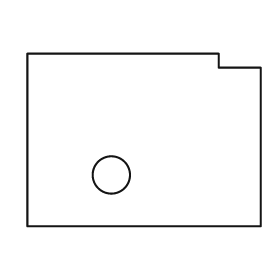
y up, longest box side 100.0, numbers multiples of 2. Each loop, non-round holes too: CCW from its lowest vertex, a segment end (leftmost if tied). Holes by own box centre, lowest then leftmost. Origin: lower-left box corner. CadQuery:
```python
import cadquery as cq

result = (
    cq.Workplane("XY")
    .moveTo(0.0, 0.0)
    .lineTo(100.0, 0.0)
    .lineTo(100.0, 68.0)
    .lineTo(82.0, 68.0)
    .lineTo(82.0, 74.0)
    .lineTo(0.0, 74.0)
    .close()
    .moveTo(36.0, 22.0)
    .circle(8.0)
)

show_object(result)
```